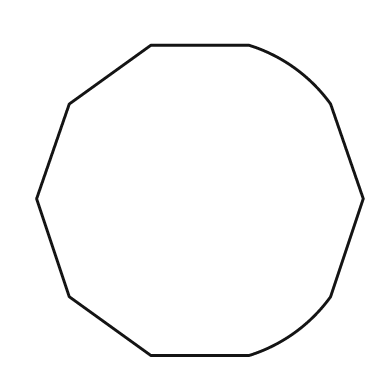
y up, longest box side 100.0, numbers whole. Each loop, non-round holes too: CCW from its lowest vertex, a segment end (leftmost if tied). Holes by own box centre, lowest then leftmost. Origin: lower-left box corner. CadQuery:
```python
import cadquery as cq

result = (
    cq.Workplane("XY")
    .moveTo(35.0, 0.0)
    .lineTo(65.0, 0.0)
    .threePointArc((79.0, 7.0), (90.0, 18.0))
    .lineTo(100.0, 48.0)
    .lineTo(90.0, 77.0)
    .threePointArc((79.0, 88.0), (65.0, 95.0))
    .lineTo(35.0, 95.0)
    .lineTo(10.0, 77.0)
    .lineTo(0.0, 48.0)
    .lineTo(10.0, 18.0)
    .close()
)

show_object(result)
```